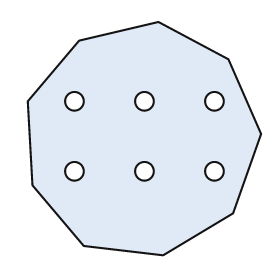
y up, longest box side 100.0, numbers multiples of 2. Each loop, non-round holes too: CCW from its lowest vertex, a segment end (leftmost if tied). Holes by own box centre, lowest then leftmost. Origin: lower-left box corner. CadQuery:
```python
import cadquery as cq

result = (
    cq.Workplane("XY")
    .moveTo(58.0, 0.0)
    .lineTo(88.0, 18.0)
    .lineTo(100.0, 52.0)
    .lineTo(86.0, 84.0)
    .lineTo(56.0, 100.0)
    .lineTo(22.0, 92.0)
    .lineTo(0.0, 66.0)
    .lineTo(2.0, 30.0)
    .lineTo(24.0, 4.0)
    .close()
    .moveTo(20.0, 36.0)
    .circle(4.0)
    .moveTo(50.0, 36.0)
    .circle(4.0)
    .moveTo(80.0, 36.0)
    .circle(4.0)
    .moveTo(20.0, 66.0)
    .circle(4.0)
    .moveTo(50.0, 66.0)
    .circle(4.0)
    .moveTo(80.0, 66.0)
    .circle(4.0)
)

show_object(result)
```